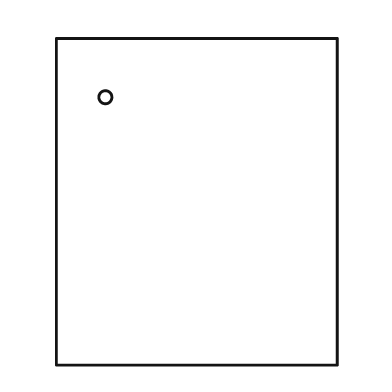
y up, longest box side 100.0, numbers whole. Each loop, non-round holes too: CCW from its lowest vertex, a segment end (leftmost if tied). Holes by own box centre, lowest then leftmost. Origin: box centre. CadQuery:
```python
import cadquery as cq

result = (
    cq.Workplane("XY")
    .moveTo(-43.0, -50.0)
    .lineTo(43.0, -50.0)
    .lineTo(43.0, 50.0)
    .lineTo(-43.0, 50.0)
    .close()
    .moveTo(-28.0, 32.0)
    .circle(2.0)
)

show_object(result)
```